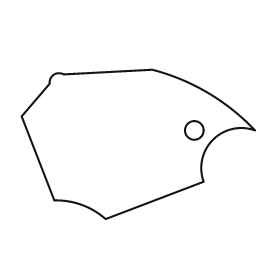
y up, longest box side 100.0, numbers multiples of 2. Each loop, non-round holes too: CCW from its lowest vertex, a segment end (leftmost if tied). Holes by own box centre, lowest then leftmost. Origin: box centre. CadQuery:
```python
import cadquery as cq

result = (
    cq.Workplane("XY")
    .moveTo(-14.0, -32.0)
    .lineTo(28.0, -16.0)
    .threePointArc((32.0, 2.0), (50.0, 6.0))
    .threePointArc((30.0, 22.0), (6.0, 32.0))
    .lineTo(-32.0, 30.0)
    .threePointArc((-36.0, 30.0), (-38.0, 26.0))
    .lineTo(-50.0, 12.0)
    .lineTo(-36.0, -24.0)
    .threePointArc((-24.0, -26.0), (-14.0, -32.0))
    .close()
    .moveTo(24.0, 6.0)
    .circle(4.0)
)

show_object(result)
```